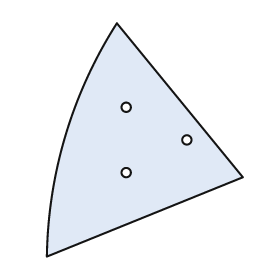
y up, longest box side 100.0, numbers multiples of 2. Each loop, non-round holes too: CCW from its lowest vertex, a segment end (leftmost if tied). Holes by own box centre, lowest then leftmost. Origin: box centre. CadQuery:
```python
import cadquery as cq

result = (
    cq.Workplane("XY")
    .moveTo(-42.0, -50.0)
    .lineTo(42.0, -16.0)
    .lineTo(-12.0, 50.0)
    .threePointArc((-34.0, 2.0), (-42.0, -50.0))
    .close()
    .moveTo(-8.0, -14.0)
    .circle(2.0)
    .moveTo(18.0, 0.0)
    .circle(2.0)
    .moveTo(-8.0, 14.0)
    .circle(2.0)
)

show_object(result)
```